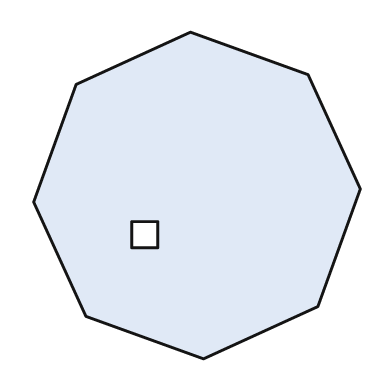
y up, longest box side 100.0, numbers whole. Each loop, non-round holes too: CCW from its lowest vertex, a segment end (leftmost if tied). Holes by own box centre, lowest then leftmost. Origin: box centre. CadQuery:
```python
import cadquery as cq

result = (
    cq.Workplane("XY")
    .moveTo(2.0, -50.0)
    .lineTo(37.0, -34.0)
    .lineTo(50.0, 2.0)
    .lineTo(34.0, 37.0)
    .lineTo(-2.0, 50.0)
    .lineTo(-37.0, 34.0)
    .lineTo(-50.0, -2.0)
    .lineTo(-34.0, -37.0)
    .close()
    .moveTo(-20.0, -16.0)
    .lineTo(-12.0, -16.0)
    .lineTo(-12.0, -8.0)
    .lineTo(-20.0, -8.0)
    .close()
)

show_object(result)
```